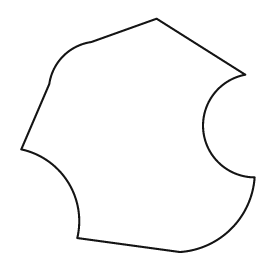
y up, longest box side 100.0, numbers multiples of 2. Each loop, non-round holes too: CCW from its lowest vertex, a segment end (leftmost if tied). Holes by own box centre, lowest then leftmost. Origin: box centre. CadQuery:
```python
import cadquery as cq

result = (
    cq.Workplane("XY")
    .moveTo(18.0, -50.0)
    .threePointArc((40.0, -40.0), (50.0, -18.0))
    .threePointArc((28.0, 2.0), (46.0, 26.0))
    .lineTo(8.0, 50.0)
    .lineTo(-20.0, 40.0)
    .threePointArc((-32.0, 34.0), (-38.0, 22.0))
    .lineTo(-50.0, -6.0)
    .threePointArc((-30.0, -20.0), (-26.0, -44.0))
    .close()
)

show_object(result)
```